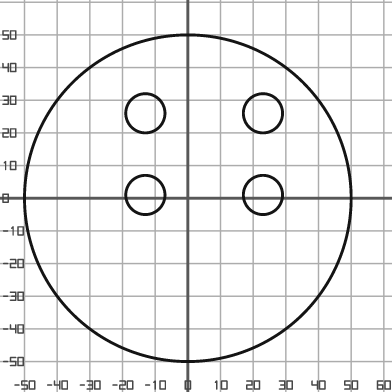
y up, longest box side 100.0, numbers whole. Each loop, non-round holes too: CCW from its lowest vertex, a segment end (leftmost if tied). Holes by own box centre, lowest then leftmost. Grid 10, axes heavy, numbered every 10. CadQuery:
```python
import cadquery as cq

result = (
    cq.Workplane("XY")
    .moveTo(0.0, 0.0)
    .circle(50.0)
    .moveTo(-13.0, 1.0)
    .circle(6.0)
    .moveTo(23.0, 1.0)
    .circle(6.0)
    .moveTo(-13.0, 26.0)
    .circle(6.0)
    .moveTo(23.0, 26.0)
    .circle(6.0)
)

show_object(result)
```